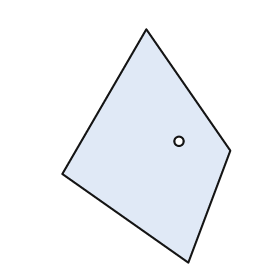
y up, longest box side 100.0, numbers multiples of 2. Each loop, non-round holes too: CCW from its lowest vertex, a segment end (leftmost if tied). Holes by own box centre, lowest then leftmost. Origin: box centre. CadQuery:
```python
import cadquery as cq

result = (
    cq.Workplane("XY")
    .moveTo(18.0, -50.0)
    .lineTo(36.0, -2.0)
    .lineTo(0.0, 50.0)
    .lineTo(-36.0, -12.0)
    .close()
    .moveTo(14.0, 2.0)
    .circle(2.0)
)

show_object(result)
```